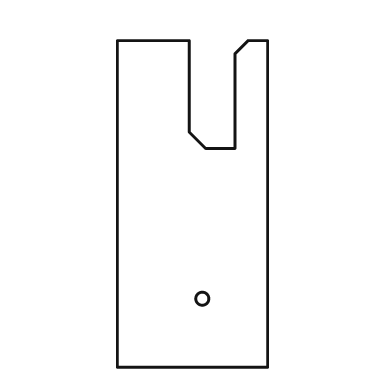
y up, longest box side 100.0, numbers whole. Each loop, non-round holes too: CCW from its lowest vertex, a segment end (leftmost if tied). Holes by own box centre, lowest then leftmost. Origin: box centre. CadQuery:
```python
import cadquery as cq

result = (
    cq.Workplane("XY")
    .moveTo(-23.0, -50.0)
    .lineTo(23.0, -50.0)
    .lineTo(23.0, 50.0)
    .lineTo(17.0, 50.0)
    .lineTo(13.0, 46.0)
    .lineTo(13.0, 17.0)
    .lineTo(4.0, 17.0)
    .lineTo(-1.0, 22.0)
    .lineTo(-1.0, 50.0)
    .lineTo(-23.0, 50.0)
    .close()
    .moveTo(3.0, -29.0)
    .circle(2.0)
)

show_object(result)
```